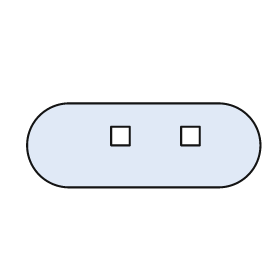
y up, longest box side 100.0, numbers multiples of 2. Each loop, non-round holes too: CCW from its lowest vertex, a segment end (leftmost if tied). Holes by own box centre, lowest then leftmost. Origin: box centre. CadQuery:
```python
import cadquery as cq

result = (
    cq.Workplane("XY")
    .moveTo(-32.0, -18.0)
    .lineTo(32.0, -18.0)
    .threePointArc((50.0, 0.0), (32.0, 18.0))
    .lineTo(-32.0, 18.0)
    .threePointArc((-50.0, 0.0), (-32.0, -18.0))
    .close()
    .moveTo(-14.0, 0.0)
    .lineTo(-6.0, 0.0)
    .lineTo(-6.0, 8.0)
    .lineTo(-14.0, 8.0)
    .close()
    .moveTo(16.0, 0.0)
    .lineTo(24.0, 0.0)
    .lineTo(24.0, 8.0)
    .lineTo(16.0, 8.0)
    .close()
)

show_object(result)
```